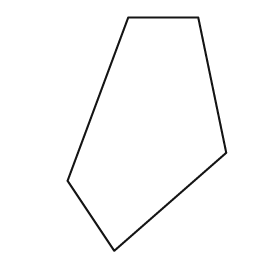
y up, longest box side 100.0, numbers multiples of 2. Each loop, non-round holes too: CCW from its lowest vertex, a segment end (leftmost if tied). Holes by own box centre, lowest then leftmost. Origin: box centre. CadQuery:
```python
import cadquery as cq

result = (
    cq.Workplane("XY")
    .moveTo(-14.0, -50.0)
    .lineTo(34.0, -8.0)
    .lineTo(22.0, 50.0)
    .lineTo(-8.0, 50.0)
    .lineTo(-34.0, -20.0)
    .close()
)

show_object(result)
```